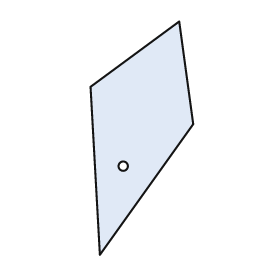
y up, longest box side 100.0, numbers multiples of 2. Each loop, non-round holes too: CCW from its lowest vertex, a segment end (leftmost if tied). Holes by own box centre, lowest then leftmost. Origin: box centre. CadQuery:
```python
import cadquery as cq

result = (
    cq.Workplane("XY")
    .moveTo(-18.0, -50.0)
    .lineTo(22.0, 6.0)
    .lineTo(16.0, 50.0)
    .lineTo(-22.0, 22.0)
    .close()
    .moveTo(-8.0, -12.0)
    .circle(2.0)
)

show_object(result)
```